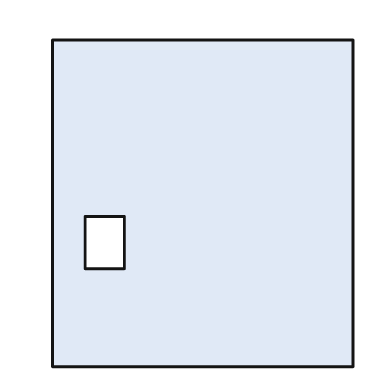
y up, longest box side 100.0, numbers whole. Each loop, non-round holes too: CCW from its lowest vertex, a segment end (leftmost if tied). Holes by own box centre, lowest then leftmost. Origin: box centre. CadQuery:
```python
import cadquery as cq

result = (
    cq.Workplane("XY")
    .moveTo(-46.0, -50.0)
    .lineTo(46.0, -50.0)
    .lineTo(46.0, 50.0)
    .lineTo(-46.0, 50.0)
    .close()
    .moveTo(-36.0, -20.0)
    .lineTo(-24.0, -20.0)
    .lineTo(-24.0, -4.0)
    .lineTo(-36.0, -4.0)
    .close()
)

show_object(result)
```